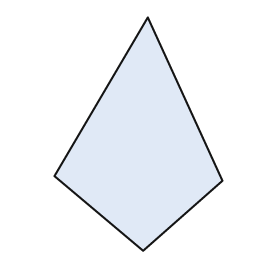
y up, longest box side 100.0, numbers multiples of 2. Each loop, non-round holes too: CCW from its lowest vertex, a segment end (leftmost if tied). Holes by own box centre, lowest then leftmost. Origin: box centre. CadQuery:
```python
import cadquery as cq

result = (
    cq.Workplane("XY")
    .moveTo(2.0, -50.0)
    .lineTo(36.0, -20.0)
    .lineTo(4.0, 50.0)
    .lineTo(-36.0, -18.0)
    .close()
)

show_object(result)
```